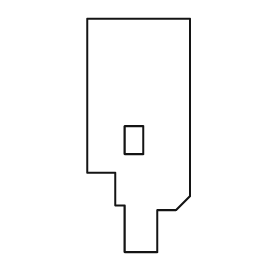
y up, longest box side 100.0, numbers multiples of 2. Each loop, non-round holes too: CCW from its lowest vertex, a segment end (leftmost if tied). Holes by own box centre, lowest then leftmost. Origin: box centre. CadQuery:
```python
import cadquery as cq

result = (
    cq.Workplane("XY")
    .moveTo(-6.0, -50.0)
    .lineTo(8.0, -50.0)
    .lineTo(8.0, -32.0)
    .lineTo(16.0, -32.0)
    .lineTo(22.0, -26.0)
    .lineTo(22.0, 50.0)
    .lineTo(-22.0, 50.0)
    .lineTo(-22.0, -16.0)
    .lineTo(-10.0, -16.0)
    .lineTo(-10.0, -30.0)
    .lineTo(-6.0, -30.0)
    .close()
    .moveTo(-6.0, -8.0)
    .lineTo(2.0, -8.0)
    .lineTo(2.0, 4.0)
    .lineTo(-6.0, 4.0)
    .close()
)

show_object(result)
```